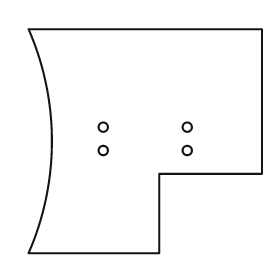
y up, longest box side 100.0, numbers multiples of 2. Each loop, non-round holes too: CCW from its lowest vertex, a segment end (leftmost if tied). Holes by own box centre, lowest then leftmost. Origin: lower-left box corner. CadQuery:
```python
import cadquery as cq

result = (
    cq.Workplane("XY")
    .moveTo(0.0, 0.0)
    .lineTo(56.0, 0.0)
    .lineTo(56.0, 34.0)
    .lineTo(100.0, 34.0)
    .lineTo(100.0, 96.0)
    .lineTo(0.0, 96.0)
    .threePointArc((10.0, 48.0), (0.0, 0.0))
    .close()
    .moveTo(32.0, 44.0)
    .circle(2.0)
    .moveTo(68.0, 44.0)
    .circle(2.0)
    .moveTo(32.0, 54.0)
    .circle(2.0)
    .moveTo(68.0, 54.0)
    .circle(2.0)
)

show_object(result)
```